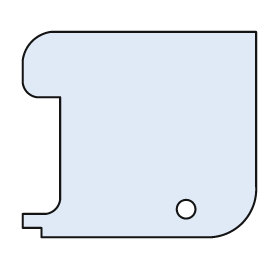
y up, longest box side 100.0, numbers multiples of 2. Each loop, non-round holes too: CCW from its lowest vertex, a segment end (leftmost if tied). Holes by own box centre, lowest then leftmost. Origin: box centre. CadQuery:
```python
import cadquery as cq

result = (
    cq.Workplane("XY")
    .moveTo(-42.0, -44.0)
    .lineTo(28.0, -44.0)
    .threePointArc((44.0, -38.0), (50.0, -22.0))
    .lineTo(50.0, 44.0)
    .lineTo(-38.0, 44.0)
    .threePointArc((-46.0, 40.0), (-50.0, 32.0))
    .lineTo(-50.0, 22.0)
    .threePointArc((-48.0, 18.0), (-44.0, 16.0))
    .lineTo(-34.0, 16.0)
    .lineTo(-34.0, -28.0)
    .threePointArc((-36.0, -32.0), (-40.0, -34.0))
    .lineTo(-50.0, -34.0)
    .lineTo(-50.0, -40.0)
    .lineTo(-42.0, -40.0)
    .close()
    .moveTo(20.0, -32.0)
    .circle(4.0)
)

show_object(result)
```